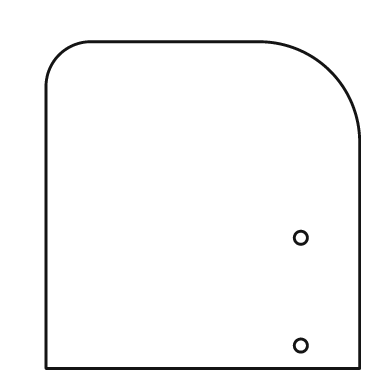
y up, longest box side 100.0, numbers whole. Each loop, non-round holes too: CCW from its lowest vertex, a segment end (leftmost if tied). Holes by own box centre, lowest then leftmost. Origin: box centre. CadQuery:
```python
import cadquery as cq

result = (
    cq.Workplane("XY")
    .moveTo(-48.0, -50.0)
    .lineTo(48.0, -50.0)
    .lineTo(48.0, 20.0)
    .threePointArc((39.0, 41.0), (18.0, 50.0))
    .lineTo(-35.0, 50.0)
    .threePointArc((-44.0, 46.0), (-48.0, 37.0))
    .close()
    .moveTo(30.0, -43.0)
    .circle(2.0)
    .moveTo(30.0, -10.0)
    .circle(2.0)
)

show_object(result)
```